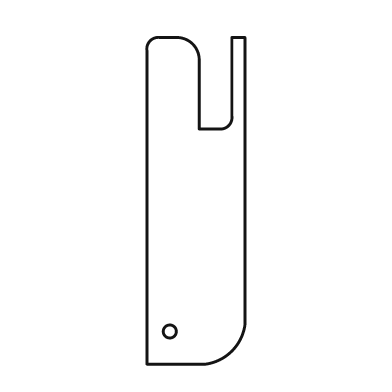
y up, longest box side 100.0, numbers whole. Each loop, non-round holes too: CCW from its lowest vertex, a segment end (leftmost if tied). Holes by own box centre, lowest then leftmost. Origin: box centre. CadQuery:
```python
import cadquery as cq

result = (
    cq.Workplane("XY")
    .moveTo(-15.0, -50.0)
    .lineTo(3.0, -50.0)
    .threePointArc((11.0, -46.0), (15.0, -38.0))
    .lineTo(15.0, 50.0)
    .lineTo(11.0, 50.0)
    .lineTo(11.0, 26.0)
    .threePointArc((10.0, 23.0), (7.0, 22.0))
    .lineTo(1.0, 22.0)
    .lineTo(1.0, 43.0)
    .threePointArc((-1.0, 48.0), (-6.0, 50.0))
    .lineTo(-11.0, 50.0)
    .threePointArc((-14.0, 49.0), (-15.0, 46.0))
    .close()
    .moveTo(-8.0, -40.0)
    .circle(2.0)
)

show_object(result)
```